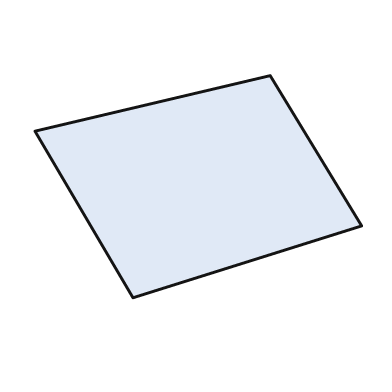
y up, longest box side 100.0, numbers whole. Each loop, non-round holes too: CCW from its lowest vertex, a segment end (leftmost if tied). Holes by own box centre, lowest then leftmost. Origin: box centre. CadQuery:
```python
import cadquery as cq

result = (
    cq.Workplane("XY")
    .moveTo(-20.0, -34.0)
    .lineTo(50.0, -12.0)
    .lineTo(22.0, 34.0)
    .lineTo(-50.0, 17.0)
    .close()
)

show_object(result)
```